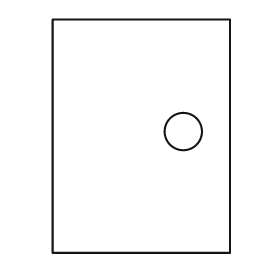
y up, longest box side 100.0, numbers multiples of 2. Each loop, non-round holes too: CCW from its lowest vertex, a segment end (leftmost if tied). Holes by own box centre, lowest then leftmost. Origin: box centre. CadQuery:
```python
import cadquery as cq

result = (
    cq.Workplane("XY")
    .moveTo(-38.0, -50.0)
    .lineTo(38.0, -50.0)
    .lineTo(38.0, 50.0)
    .lineTo(-38.0, 50.0)
    .close()
    .moveTo(18.0, 2.0)
    .circle(8.0)
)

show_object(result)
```